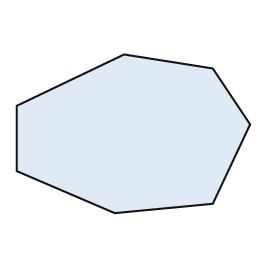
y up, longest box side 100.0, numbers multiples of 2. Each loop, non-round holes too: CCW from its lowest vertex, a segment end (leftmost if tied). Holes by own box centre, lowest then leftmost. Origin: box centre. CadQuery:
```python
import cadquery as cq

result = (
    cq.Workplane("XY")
    .moveTo(-8.0, -34.0)
    .lineTo(34.0, -30.0)
    .lineTo(50.0, 4.0)
    .lineTo(34.0, 28.0)
    .lineTo(-4.0, 34.0)
    .lineTo(-50.0, 12.0)
    .lineTo(-50.0, -16.0)
    .close()
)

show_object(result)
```